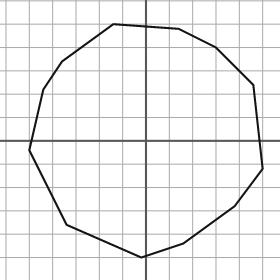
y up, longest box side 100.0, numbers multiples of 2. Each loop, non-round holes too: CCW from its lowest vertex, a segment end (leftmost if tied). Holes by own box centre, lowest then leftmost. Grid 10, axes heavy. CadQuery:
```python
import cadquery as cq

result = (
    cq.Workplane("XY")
    .moveTo(-2.0, -50.0)
    .lineTo(16.0, -44.0)
    .lineTo(38.0, -28.0)
    .lineTo(50.0, -12.0)
    .lineTo(46.0, 24.0)
    .lineTo(30.0, 40.0)
    .lineTo(14.0, 48.0)
    .lineTo(-14.0, 50.0)
    .lineTo(-36.0, 34.0)
    .lineTo(-44.0, 22.0)
    .lineTo(-50.0, -4.0)
    .lineTo(-34.0, -36.0)
    .close()
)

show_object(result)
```